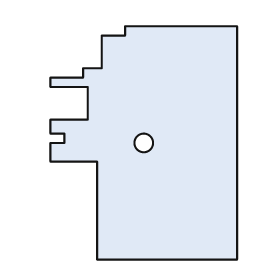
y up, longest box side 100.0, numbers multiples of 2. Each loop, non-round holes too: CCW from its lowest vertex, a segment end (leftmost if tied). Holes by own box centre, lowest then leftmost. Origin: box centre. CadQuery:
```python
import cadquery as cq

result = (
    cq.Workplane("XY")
    .moveTo(-20.0, -50.0)
    .lineTo(40.0, -50.0)
    .lineTo(40.0, 50.0)
    .lineTo(-8.0, 50.0)
    .lineTo(-8.0, 46.0)
    .lineTo(-18.0, 46.0)
    .lineTo(-18.0, 32.0)
    .lineTo(-26.0, 32.0)
    .lineTo(-26.0, 28.0)
    .lineTo(-40.0, 28.0)
    .lineTo(-40.0, 24.0)
    .lineTo(-24.0, 24.0)
    .lineTo(-24.0, 10.0)
    .lineTo(-40.0, 10.0)
    .lineTo(-40.0, 4.0)
    .lineTo(-34.0, 4.0)
    .lineTo(-34.0, 0.0)
    .lineTo(-40.0, 0.0)
    .lineTo(-40.0, -8.0)
    .lineTo(-20.0, -8.0)
    .close()
    .moveTo(0.0, 0.0)
    .circle(4.0)
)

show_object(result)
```